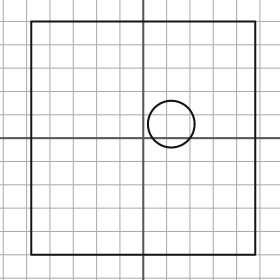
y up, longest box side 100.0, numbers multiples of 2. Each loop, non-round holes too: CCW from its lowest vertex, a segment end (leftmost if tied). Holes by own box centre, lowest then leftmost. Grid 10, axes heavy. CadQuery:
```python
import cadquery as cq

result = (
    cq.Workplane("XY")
    .moveTo(-48.0, -50.0)
    .lineTo(48.0, -50.0)
    .lineTo(48.0, 50.0)
    .lineTo(-48.0, 50.0)
    .close()
    .moveTo(12.0, 6.0)
    .circle(10.0)
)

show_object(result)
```